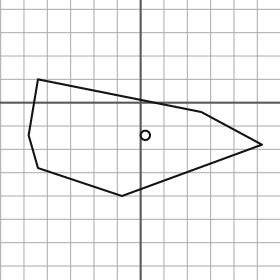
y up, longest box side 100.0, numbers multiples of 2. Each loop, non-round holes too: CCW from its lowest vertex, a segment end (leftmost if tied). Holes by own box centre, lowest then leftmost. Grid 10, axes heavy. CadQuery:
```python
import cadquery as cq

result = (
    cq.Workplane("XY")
    .moveTo(-8.0, -40.0)
    .lineTo(52.0, -18.0)
    .lineTo(26.0, -4.0)
    .lineTo(-44.0, 10.0)
    .lineTo(-48.0, -14.0)
    .lineTo(-44.0, -28.0)
    .close()
    .moveTo(2.0, -14.0)
    .circle(2.0)
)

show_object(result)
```